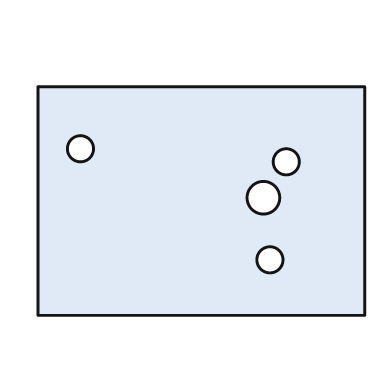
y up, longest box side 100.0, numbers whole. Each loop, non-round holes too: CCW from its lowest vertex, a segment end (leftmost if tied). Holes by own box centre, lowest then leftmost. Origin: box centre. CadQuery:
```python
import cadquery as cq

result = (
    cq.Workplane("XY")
    .moveTo(-50.0, -35.0)
    .lineTo(50.0, -35.0)
    .lineTo(50.0, 35.0)
    .lineTo(-50.0, 35.0)
    .close()
    .moveTo(21.0, -18.0)
    .circle(4.0)
    .moveTo(19.0, 1.0)
    .circle(5.0)
    .moveTo(26.0, 12.0)
    .circle(4.0)
    .moveTo(-37.0, 16.0)
    .circle(4.0)
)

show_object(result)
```